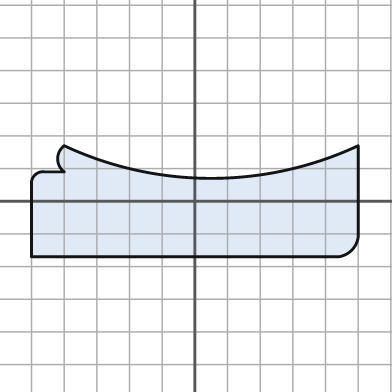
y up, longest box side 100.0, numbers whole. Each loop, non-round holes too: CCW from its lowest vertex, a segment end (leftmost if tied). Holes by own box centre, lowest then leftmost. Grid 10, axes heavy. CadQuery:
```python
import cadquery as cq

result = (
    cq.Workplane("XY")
    .moveTo(-50.0, -17.0)
    .lineTo(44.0, -17.0)
    .threePointArc((48.0, -15.0), (50.0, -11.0))
    .lineTo(50.0, 17.0)
    .threePointArc((5.0, 7.0), (-40.0, 17.0))
    .threePointArc((-42.0, 13.0), (-40.0, 9.0))
    .lineTo(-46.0, 9.0)
    .threePointArc((-49.0, 8.0), (-50.0, 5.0))
    .close()
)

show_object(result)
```